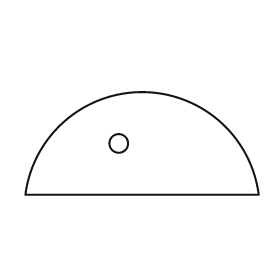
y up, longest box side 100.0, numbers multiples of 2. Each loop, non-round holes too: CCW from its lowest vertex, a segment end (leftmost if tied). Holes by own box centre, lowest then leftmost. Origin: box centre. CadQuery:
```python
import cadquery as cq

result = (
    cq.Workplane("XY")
    .moveTo(-50.0, -22.0)
    .lineTo(50.0, -22.0)
    .threePointArc((0.0, 22.0), (-50.0, -22.0))
    .close()
    .moveTo(-10.0, 0.0)
    .circle(4.0)
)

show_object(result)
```